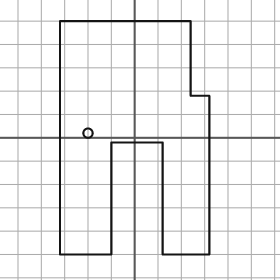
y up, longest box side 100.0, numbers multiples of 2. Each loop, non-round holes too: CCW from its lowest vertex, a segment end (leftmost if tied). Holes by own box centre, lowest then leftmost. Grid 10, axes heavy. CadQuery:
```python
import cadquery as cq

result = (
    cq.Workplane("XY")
    .moveTo(-32.0, -50.0)
    .lineTo(-10.0, -50.0)
    .lineTo(-10.0, -2.0)
    .lineTo(12.0, -2.0)
    .lineTo(12.0, -50.0)
    .lineTo(32.0, -50.0)
    .lineTo(32.0, 18.0)
    .lineTo(24.0, 18.0)
    .lineTo(24.0, 50.0)
    .lineTo(-32.0, 50.0)
    .close()
    .moveTo(-20.0, 2.0)
    .circle(2.0)
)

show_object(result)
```